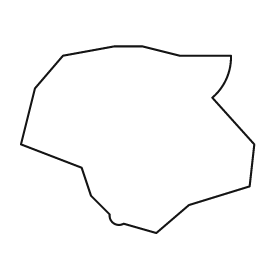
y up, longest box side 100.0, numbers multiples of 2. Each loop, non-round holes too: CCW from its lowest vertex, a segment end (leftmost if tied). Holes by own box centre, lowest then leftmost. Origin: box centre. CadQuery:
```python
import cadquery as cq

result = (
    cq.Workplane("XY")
    .moveTo(8.0, -40.0)
    .lineTo(22.0, -28.0)
    .lineTo(48.0, -20.0)
    .lineTo(50.0, -2.0)
    .lineTo(32.0, 18.0)
    .threePointArc((38.0, 26.0), (40.0, 36.0))
    .lineTo(18.0, 36.0)
    .lineTo(2.0, 40.0)
    .lineTo(-10.0, 40.0)
    .lineTo(-32.0, 36.0)
    .lineTo(-44.0, 22.0)
    .lineTo(-50.0, -2.0)
    .lineTo(-24.0, -12.0)
    .lineTo(-20.0, -24.0)
    .lineTo(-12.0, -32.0)
    .threePointArc((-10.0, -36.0), (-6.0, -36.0))
    .close()
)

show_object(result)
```